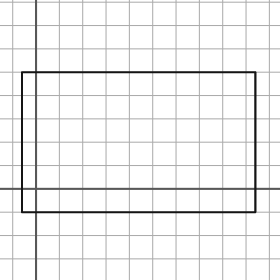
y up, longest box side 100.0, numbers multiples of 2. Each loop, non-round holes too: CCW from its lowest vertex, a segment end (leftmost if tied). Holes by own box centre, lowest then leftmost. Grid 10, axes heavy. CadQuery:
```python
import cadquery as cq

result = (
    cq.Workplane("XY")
    .moveTo(-6.0, -10.0)
    .lineTo(94.0, -10.0)
    .lineTo(94.0, 50.0)
    .lineTo(-6.0, 50.0)
    .close()
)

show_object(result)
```